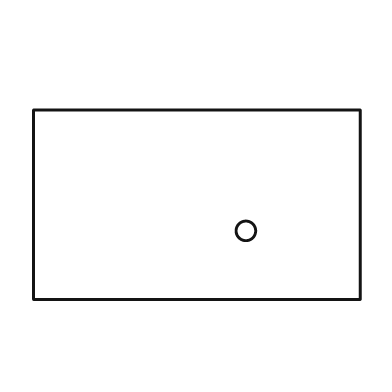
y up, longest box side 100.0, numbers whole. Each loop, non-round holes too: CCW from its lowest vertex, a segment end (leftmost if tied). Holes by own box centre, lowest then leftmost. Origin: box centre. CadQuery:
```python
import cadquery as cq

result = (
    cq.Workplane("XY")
    .moveTo(-50.0, -29.0)
    .lineTo(50.0, -29.0)
    .lineTo(50.0, 29.0)
    .lineTo(-50.0, 29.0)
    .close()
    .moveTo(15.0, -8.0)
    .circle(3.0)
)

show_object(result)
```